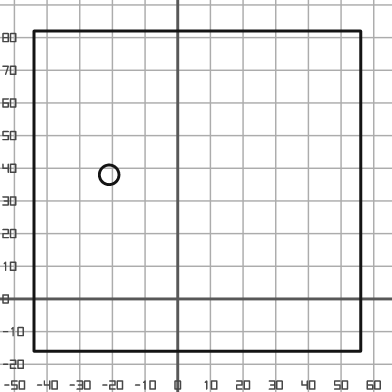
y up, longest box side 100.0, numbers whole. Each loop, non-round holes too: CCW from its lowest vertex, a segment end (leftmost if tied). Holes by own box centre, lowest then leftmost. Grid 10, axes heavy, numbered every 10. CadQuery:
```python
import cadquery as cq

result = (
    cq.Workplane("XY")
    .moveTo(-44.0, -16.0)
    .lineTo(56.0, -16.0)
    .lineTo(56.0, 82.0)
    .lineTo(-44.0, 82.0)
    .close()
    .moveTo(-21.0, 38.0)
    .circle(3.0)
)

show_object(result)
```